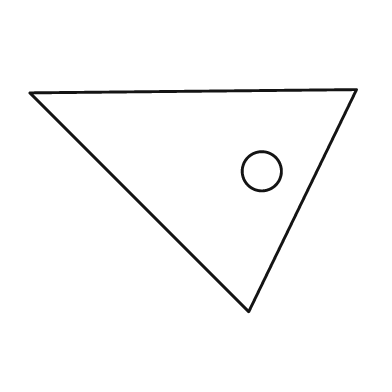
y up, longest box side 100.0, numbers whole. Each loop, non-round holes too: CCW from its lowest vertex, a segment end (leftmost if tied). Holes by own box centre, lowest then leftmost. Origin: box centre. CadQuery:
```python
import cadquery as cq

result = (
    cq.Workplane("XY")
    .moveTo(17.0, -34.0)
    .lineTo(50.0, 34.0)
    .lineTo(-50.0, 33.0)
    .close()
    .moveTo(21.0, 9.0)
    .circle(6.0)
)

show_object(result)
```